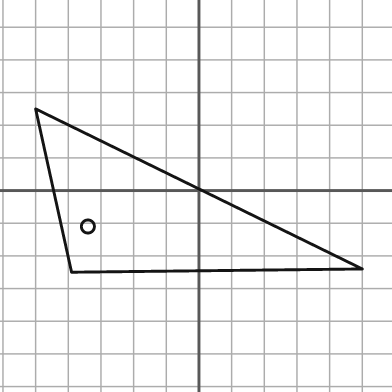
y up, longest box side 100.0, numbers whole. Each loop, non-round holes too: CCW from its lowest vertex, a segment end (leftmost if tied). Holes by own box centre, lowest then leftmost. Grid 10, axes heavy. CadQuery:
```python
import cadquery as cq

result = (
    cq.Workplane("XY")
    .moveTo(-39.0, -25.0)
    .lineTo(50.0, -24.0)
    .lineTo(-50.0, 25.0)
    .close()
    .moveTo(-34.0, -11.0)
    .circle(2.0)
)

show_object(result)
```